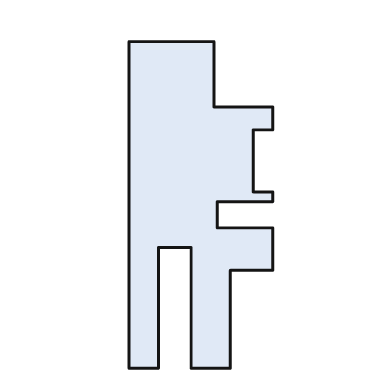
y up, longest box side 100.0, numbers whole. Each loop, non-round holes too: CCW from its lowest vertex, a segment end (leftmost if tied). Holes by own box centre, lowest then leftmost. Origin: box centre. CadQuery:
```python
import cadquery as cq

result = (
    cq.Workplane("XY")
    .moveTo(-22.0, -50.0)
    .lineTo(-13.0, -50.0)
    .lineTo(-13.0, -13.0)
    .lineTo(-3.0, -13.0)
    .lineTo(-3.0, -50.0)
    .lineTo(9.0, -50.0)
    .lineTo(9.0, -20.0)
    .lineTo(22.0, -20.0)
    .lineTo(22.0, -7.0)
    .lineTo(5.0, -7.0)
    .lineTo(5.0, 1.0)
    .lineTo(22.0, 1.0)
    .lineTo(22.0, 4.0)
    .lineTo(16.0, 4.0)
    .lineTo(16.0, 23.0)
    .lineTo(22.0, 23.0)
    .lineTo(22.0, 30.0)
    .lineTo(4.0, 30.0)
    .lineTo(4.0, 50.0)
    .lineTo(-22.0, 50.0)
    .close()
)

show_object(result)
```